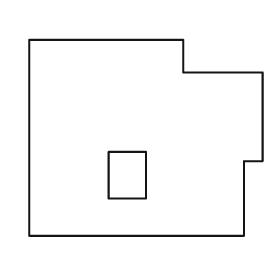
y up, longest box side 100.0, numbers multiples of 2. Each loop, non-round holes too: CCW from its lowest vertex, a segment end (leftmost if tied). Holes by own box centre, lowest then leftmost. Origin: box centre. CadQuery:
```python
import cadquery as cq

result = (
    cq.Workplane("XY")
    .moveTo(-50.0, -42.0)
    .lineTo(42.0, -42.0)
    .lineTo(42.0, -10.0)
    .lineTo(50.0, -10.0)
    .lineTo(50.0, 28.0)
    .lineTo(16.0, 28.0)
    .lineTo(16.0, 42.0)
    .lineTo(-50.0, 42.0)
    .close()
    .moveTo(-16.0, -26.0)
    .lineTo(0.0, -26.0)
    .lineTo(0.0, -6.0)
    .lineTo(-16.0, -6.0)
    .close()
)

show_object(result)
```